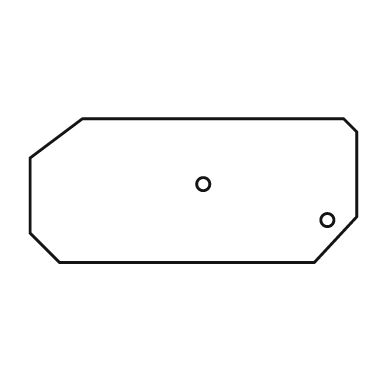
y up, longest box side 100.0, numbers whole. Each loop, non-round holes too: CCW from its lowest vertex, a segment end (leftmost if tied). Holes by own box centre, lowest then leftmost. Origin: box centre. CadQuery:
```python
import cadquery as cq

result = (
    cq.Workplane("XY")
    .moveTo(-41.0, -22.0)
    .lineTo(37.0, -22.0)
    .lineTo(50.0, -8.0)
    .lineTo(50.0, 18.0)
    .lineTo(46.0, 22.0)
    .lineTo(-34.0, 22.0)
    .lineTo(-50.0, 10.0)
    .lineTo(-50.0, -13.0)
    .close()
    .moveTo(41.0, -9.0)
    .circle(2.0)
    .moveTo(3.0, 2.0)
    .circle(2.0)
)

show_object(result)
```